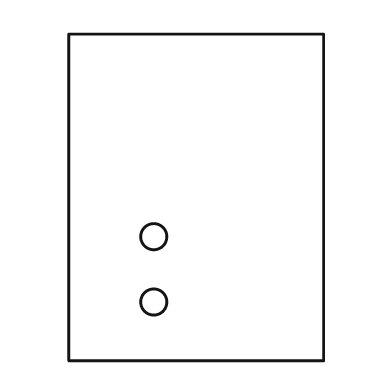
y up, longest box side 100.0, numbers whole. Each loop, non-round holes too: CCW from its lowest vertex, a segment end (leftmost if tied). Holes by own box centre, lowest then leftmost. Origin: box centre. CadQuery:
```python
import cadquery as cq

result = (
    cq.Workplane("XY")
    .moveTo(-39.0, -50.0)
    .lineTo(39.0, -50.0)
    .lineTo(39.0, 50.0)
    .lineTo(-39.0, 50.0)
    .close()
    .moveTo(-13.0, -32.0)
    .circle(4.0)
    .moveTo(-13.0, -12.0)
    .circle(4.0)
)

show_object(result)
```